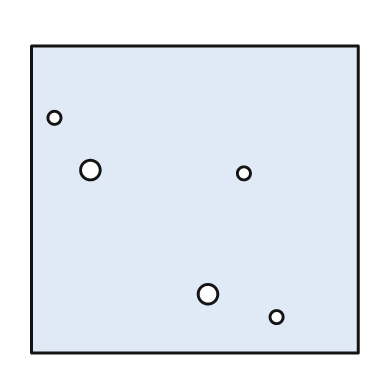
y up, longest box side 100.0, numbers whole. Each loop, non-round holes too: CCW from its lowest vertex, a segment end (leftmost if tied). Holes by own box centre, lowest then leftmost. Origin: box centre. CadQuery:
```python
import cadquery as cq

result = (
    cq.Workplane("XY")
    .moveTo(-50.0, -47.0)
    .lineTo(50.0, -47.0)
    .lineTo(50.0, 47.0)
    .lineTo(-50.0, 47.0)
    .close()
    .moveTo(25.0, -36.0)
    .circle(2.0)
    .moveTo(4.0, -29.0)
    .circle(3.0)
    .moveTo(15.0, 8.0)
    .circle(2.0)
    .moveTo(-32.0, 9.0)
    .circle(3.0)
    .moveTo(-43.0, 25.0)
    .circle(2.0)
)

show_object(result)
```